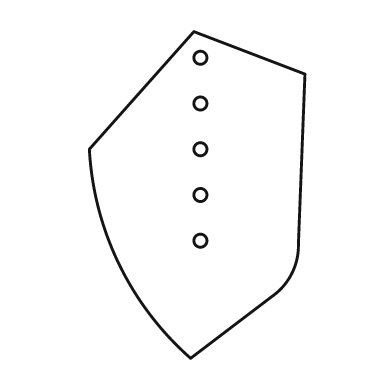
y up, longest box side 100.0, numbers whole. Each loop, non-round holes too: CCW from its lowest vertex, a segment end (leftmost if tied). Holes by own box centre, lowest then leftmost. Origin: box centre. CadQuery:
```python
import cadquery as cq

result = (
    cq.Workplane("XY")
    .moveTo(-2.0, -50.0)
    .lineTo(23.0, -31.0)
    .threePointArc((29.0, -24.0), (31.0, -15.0))
    .lineTo(33.0, 37.0)
    .lineTo(-1.0, 50.0)
    .lineTo(-33.0, 14.0)
    .threePointArc((-24.0, -21.0), (-2.0, -50.0))
    .close()
    .moveTo(1.0, -14.0)
    .circle(2.0)
    .moveTo(1.0, 0.0)
    .circle(2.0)
    .moveTo(1.0, 14.0)
    .circle(2.0)
    .moveTo(1.0, 28.0)
    .circle(2.0)
    .moveTo(1.0, 42.0)
    .circle(2.0)
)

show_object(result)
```